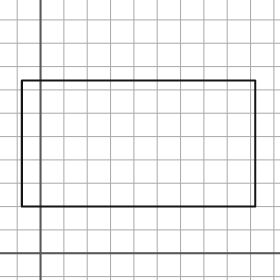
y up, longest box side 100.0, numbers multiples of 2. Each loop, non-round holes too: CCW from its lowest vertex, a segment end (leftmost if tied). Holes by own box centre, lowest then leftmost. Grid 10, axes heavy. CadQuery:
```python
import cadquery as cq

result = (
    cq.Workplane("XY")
    .moveTo(-8.0, 20.0)
    .lineTo(92.0, 20.0)
    .lineTo(92.0, 74.0)
    .lineTo(-8.0, 74.0)
    .close()
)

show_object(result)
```